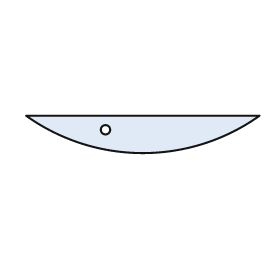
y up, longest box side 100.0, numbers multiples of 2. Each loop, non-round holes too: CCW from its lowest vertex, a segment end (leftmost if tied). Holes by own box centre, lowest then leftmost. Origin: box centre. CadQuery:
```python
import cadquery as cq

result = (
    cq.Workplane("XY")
    .moveTo(-50.0, 8.0)
    .threePointArc((0.0, -8.0), (50.0, 8.0))
    .close()
    .moveTo(-16.0, 2.0)
    .circle(2.0)
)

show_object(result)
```